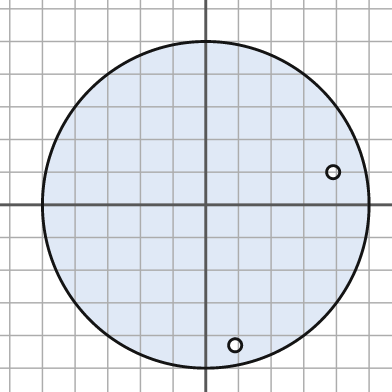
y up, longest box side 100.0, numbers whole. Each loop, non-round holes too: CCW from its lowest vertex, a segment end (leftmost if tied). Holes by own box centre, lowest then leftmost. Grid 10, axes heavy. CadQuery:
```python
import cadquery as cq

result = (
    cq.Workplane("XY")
    .moveTo(0.0, 0.0)
    .circle(50.0)
    .moveTo(9.0, -43.0)
    .circle(2.0)
    .moveTo(39.0, 10.0)
    .circle(2.0)
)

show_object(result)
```